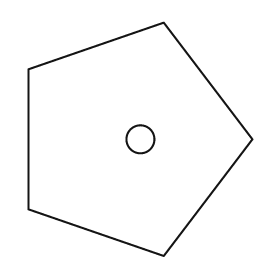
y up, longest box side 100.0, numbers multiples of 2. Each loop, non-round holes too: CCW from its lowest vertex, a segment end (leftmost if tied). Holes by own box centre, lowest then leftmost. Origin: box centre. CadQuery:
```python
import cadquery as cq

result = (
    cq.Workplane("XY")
    .moveTo(10.0, -50.0)
    .lineTo(48.0, 0.0)
    .lineTo(10.0, 50.0)
    .lineTo(-48.0, 30.0)
    .lineTo(-48.0, -30.0)
    .close()
    .moveTo(0.0, 0.0)
    .circle(6.0)
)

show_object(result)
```